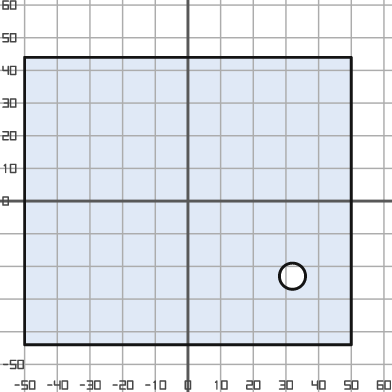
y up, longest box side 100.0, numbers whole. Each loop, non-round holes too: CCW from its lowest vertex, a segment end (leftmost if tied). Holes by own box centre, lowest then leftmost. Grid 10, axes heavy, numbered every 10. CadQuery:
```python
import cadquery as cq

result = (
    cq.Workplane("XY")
    .moveTo(-50.0, -44.0)
    .lineTo(50.0, -44.0)
    .lineTo(50.0, 44.0)
    .lineTo(-50.0, 44.0)
    .close()
    .moveTo(32.0, -23.0)
    .circle(4.0)
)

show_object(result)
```